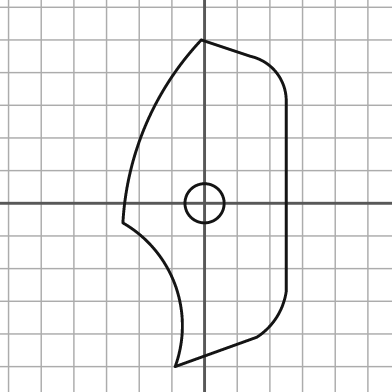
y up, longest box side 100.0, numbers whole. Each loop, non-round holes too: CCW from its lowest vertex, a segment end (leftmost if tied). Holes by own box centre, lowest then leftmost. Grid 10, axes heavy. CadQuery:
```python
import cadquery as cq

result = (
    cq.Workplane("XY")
    .moveTo(-9.0, -50.0)
    .lineTo(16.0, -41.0)
    .threePointArc((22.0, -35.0), (25.0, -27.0))
    .lineTo(25.0, 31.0)
    .threePointArc((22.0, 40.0), (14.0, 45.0))
    .lineTo(-1.0, 50.0)
    .threePointArc((-18.0, 24.0), (-25.0, -6.0))
    .threePointArc((-9.0, -25.0), (-9.0, -50.0))
    .close()
    .moveTo(0.0, 0.0)
    .circle(6.0)
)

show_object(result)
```